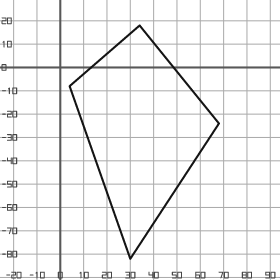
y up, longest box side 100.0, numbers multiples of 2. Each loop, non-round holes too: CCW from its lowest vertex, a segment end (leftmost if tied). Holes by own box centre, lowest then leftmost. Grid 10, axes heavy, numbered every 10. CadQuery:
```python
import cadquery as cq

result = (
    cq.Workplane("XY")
    .moveTo(30.0, -82.0)
    .lineTo(68.0, -24.0)
    .lineTo(34.0, 18.0)
    .lineTo(4.0, -8.0)
    .close()
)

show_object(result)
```